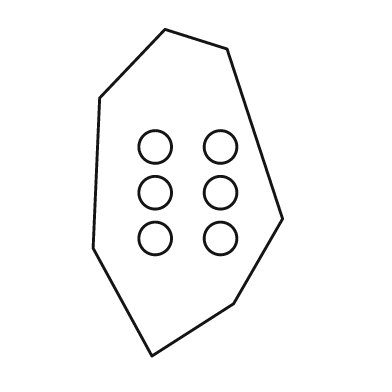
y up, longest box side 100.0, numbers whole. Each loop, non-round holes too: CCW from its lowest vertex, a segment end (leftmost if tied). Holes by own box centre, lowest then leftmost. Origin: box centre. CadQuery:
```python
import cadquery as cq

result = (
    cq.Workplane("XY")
    .moveTo(-11.0, -50.0)
    .lineTo(14.0, -34.0)
    .lineTo(29.0, -8.0)
    .lineTo(12.0, 44.0)
    .lineTo(-7.0, 50.0)
    .lineTo(-27.0, 29.0)
    .lineTo(-29.0, -17.0)
    .close()
    .moveTo(-10.0, -14.0)
    .circle(5.0)
    .moveTo(10.0, -14.0)
    .circle(5.0)
    .moveTo(-10.0, 0.0)
    .circle(5.0)
    .moveTo(10.0, 0.0)
    .circle(5.0)
    .moveTo(-10.0, 14.0)
    .circle(5.0)
    .moveTo(10.0, 14.0)
    .circle(5.0)
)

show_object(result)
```